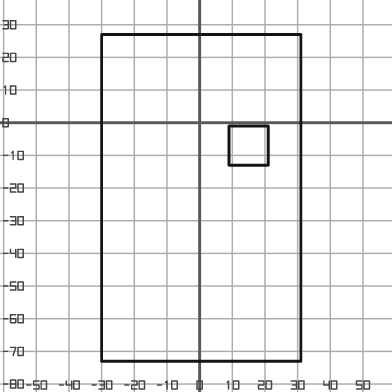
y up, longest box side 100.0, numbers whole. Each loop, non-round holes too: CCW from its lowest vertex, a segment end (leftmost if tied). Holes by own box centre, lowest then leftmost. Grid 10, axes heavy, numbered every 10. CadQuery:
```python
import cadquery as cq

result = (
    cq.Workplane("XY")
    .moveTo(-30.0, -73.0)
    .lineTo(31.0, -73.0)
    .lineTo(31.0, 27.0)
    .lineTo(-30.0, 27.0)
    .close()
    .moveTo(9.0, -13.0)
    .lineTo(21.0, -13.0)
    .lineTo(21.0, -1.0)
    .lineTo(9.0, -1.0)
    .close()
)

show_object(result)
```